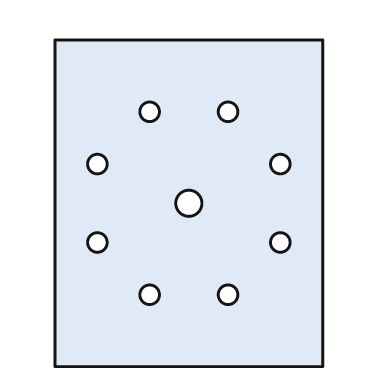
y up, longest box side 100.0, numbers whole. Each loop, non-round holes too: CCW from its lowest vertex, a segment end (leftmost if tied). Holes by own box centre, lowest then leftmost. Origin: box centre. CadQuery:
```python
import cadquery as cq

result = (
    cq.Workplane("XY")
    .moveTo(-41.0, -50.0)
    .lineTo(41.0, -50.0)
    .lineTo(41.0, 50.0)
    .lineTo(-41.0, 50.0)
    .close()
    .moveTo(-12.0, -28.0)
    .circle(3.0)
    .moveTo(12.0, -28.0)
    .circle(3.0)
    .moveTo(-28.0, -12.0)
    .circle(3.0)
    .moveTo(28.0, -12.0)
    .circle(3.0)
    .moveTo(0.0, 0.0)
    .circle(4.0)
    .moveTo(-28.0, 12.0)
    .circle(3.0)
    .moveTo(28.0, 12.0)
    .circle(3.0)
    .moveTo(-12.0, 28.0)
    .circle(3.0)
    .moveTo(12.0, 28.0)
    .circle(3.0)
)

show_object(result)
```